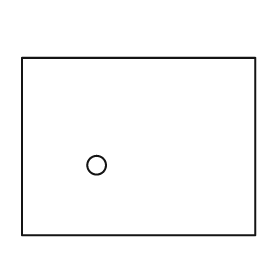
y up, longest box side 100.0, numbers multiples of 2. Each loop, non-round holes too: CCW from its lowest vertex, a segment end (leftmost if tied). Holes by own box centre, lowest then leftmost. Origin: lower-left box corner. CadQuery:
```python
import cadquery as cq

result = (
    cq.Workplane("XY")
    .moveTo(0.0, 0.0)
    .lineTo(100.0, 0.0)
    .lineTo(100.0, 76.0)
    .lineTo(0.0, 76.0)
    .close()
    .moveTo(32.0, 30.0)
    .circle(4.0)
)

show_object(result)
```